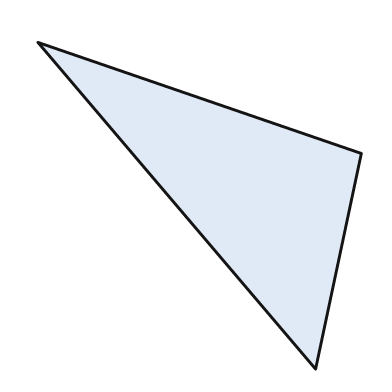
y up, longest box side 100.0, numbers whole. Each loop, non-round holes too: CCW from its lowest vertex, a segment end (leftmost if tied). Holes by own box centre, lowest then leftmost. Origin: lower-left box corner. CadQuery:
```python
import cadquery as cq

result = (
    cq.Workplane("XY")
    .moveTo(85.0, 0.0)
    .lineTo(99.0, 66.0)
    .lineTo(0.0, 100.0)
    .close()
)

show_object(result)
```